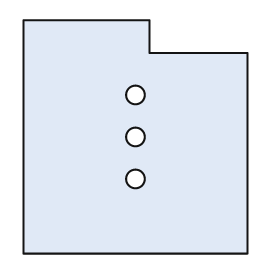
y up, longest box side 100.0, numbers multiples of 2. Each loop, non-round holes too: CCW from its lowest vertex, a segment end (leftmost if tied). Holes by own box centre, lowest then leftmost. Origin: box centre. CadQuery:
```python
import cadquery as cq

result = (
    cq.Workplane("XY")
    .moveTo(-48.0, -50.0)
    .lineTo(48.0, -50.0)
    .lineTo(48.0, 36.0)
    .lineTo(6.0, 36.0)
    .lineTo(6.0, 50.0)
    .lineTo(-48.0, 50.0)
    .close()
    .moveTo(0.0, -18.0)
    .circle(4.0)
    .moveTo(0.0, 0.0)
    .circle(4.0)
    .moveTo(0.0, 18.0)
    .circle(4.0)
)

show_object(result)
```